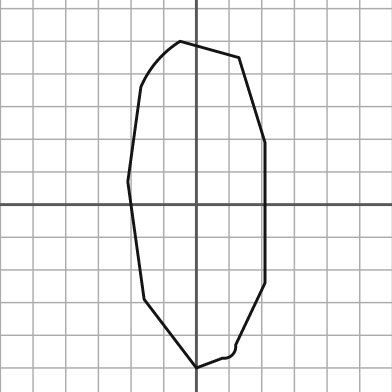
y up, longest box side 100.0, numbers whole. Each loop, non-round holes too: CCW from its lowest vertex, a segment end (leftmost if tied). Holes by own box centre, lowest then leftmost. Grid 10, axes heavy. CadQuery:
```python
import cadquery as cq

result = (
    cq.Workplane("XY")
    .moveTo(0.0, -50.0)
    .lineTo(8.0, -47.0)
    .threePointArc((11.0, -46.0), (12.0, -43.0))
    .lineTo(21.0, -24.0)
    .lineTo(21.0, 19.0)
    .lineTo(13.0, 45.0)
    .lineTo(-5.0, 50.0)
    .threePointArc((-12.0, 44.0), (-17.0, 36.0))
    .lineTo(-21.0, 7.0)
    .lineTo(-16.0, -29.0)
    .close()
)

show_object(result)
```